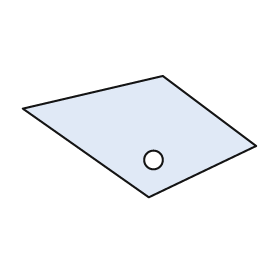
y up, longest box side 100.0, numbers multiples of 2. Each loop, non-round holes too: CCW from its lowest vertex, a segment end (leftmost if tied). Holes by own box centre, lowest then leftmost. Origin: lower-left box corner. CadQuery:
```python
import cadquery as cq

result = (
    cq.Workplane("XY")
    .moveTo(54.0, 0.0)
    .lineTo(100.0, 22.0)
    .lineTo(60.0, 52.0)
    .lineTo(0.0, 38.0)
    .close()
    .moveTo(56.0, 16.0)
    .circle(4.0)
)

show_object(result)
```